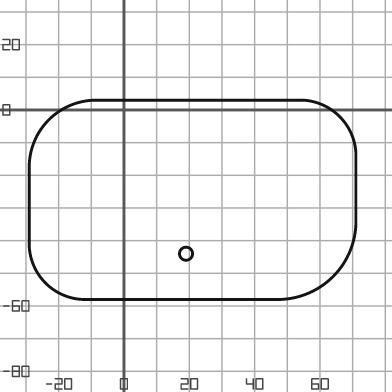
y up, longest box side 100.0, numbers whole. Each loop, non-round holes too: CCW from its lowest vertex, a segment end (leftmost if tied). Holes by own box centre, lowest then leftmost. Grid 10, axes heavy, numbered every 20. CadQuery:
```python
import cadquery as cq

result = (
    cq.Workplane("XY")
    .moveTo(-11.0, -58.0)
    .lineTo(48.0, -58.0)
    .threePointArc((64.0, -51.0), (71.0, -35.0))
    .lineTo(71.0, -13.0)
    .threePointArc((66.0, -2.0), (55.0, 3.0))
    .lineTo(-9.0, 3.0)
    .threePointArc((-23.0, -3.0), (-29.0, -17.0))
    .lineTo(-29.0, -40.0)
    .threePointArc((-24.0, -53.0), (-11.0, -58.0))
    .close()
    .moveTo(19.0, -44.0)
    .circle(2.0)
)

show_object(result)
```